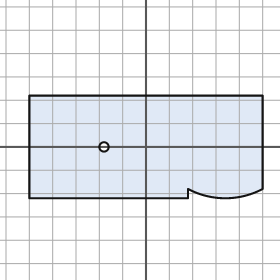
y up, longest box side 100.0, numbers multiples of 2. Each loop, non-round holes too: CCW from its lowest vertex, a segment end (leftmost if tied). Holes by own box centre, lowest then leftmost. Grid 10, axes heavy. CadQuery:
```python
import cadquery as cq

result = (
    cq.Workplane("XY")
    .moveTo(-50.0, -22.0)
    .lineTo(18.0, -22.0)
    .lineTo(18.0, -18.0)
    .threePointArc((34.0, -22.0), (50.0, -18.0))
    .lineTo(50.0, 22.0)
    .lineTo(-50.0, 22.0)
    .close()
    .moveTo(-18.0, 0.0)
    .circle(2.0)
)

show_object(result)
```